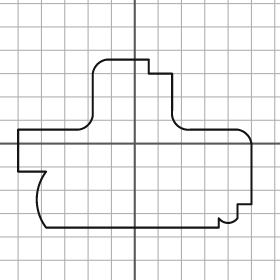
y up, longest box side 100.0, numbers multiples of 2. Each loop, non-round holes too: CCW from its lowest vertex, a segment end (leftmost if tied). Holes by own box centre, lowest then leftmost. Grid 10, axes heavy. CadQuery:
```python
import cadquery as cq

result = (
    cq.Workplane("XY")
    .moveTo(-38.0, -36.0)
    .lineTo(36.0, -36.0)
    .lineTo(36.0, -32.0)
    .threePointArc((40.0, -34.0), (44.0, -32.0))
    .lineTo(44.0, -26.0)
    .lineTo(50.0, -26.0)
    .lineTo(50.0, 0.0)
    .threePointArc((48.0, 4.0), (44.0, 6.0))
    .lineTo(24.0, 6.0)
    .threePointArc((18.0, 8.0), (16.0, 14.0))
    .lineTo(16.0, 30.0)
    .lineTo(6.0, 30.0)
    .lineTo(6.0, 36.0)
    .lineTo(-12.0, 36.0)
    .threePointArc((-16.0, 34.0), (-18.0, 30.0))
    .lineTo(-18.0, 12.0)
    .threePointArc((-20.0, 8.0), (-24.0, 6.0))
    .lineTo(-50.0, 6.0)
    .lineTo(-50.0, -12.0)
    .lineTo(-38.0, -12.0)
    .threePointArc((-42.0, -24.0), (-38.0, -36.0))
    .close()
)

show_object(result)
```